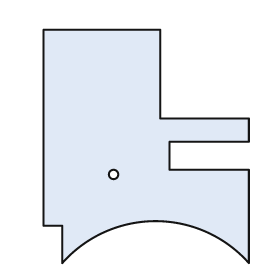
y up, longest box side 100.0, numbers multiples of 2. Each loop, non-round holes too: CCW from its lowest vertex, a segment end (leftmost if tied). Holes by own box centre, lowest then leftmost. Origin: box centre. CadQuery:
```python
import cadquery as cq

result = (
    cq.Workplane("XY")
    .moveTo(-36.0, -50.0)
    .threePointArc((4.0, -32.0), (44.0, -50.0))
    .lineTo(44.0, -10.0)
    .lineTo(10.0, -10.0)
    .lineTo(10.0, 2.0)
    .lineTo(44.0, 2.0)
    .lineTo(44.0, 12.0)
    .lineTo(6.0, 12.0)
    .lineTo(6.0, 50.0)
    .lineTo(-44.0, 50.0)
    .lineTo(-44.0, -34.0)
    .lineTo(-36.0, -34.0)
    .close()
    .moveTo(-14.0, -12.0)
    .circle(2.0)
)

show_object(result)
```